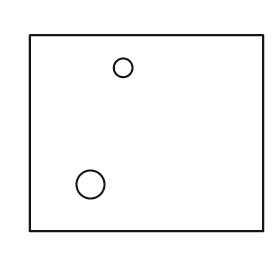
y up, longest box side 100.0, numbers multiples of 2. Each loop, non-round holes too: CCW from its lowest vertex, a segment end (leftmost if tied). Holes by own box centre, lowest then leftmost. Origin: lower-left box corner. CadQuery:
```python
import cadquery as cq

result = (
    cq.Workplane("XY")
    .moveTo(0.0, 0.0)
    .lineTo(100.0, 0.0)
    .lineTo(100.0, 84.0)
    .lineTo(0.0, 84.0)
    .close()
    .moveTo(26.0, 20.0)
    .circle(6.0)
    .moveTo(40.0, 70.0)
    .circle(4.0)
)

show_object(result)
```